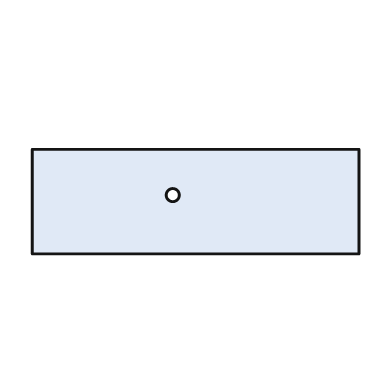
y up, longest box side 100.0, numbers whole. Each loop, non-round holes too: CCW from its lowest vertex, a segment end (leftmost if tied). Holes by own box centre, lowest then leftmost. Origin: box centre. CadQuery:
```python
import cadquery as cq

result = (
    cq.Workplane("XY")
    .moveTo(-50.0, -16.0)
    .lineTo(50.0, -16.0)
    .lineTo(50.0, 16.0)
    .lineTo(-50.0, 16.0)
    .close()
    .moveTo(-7.0, 2.0)
    .circle(2.0)
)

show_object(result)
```